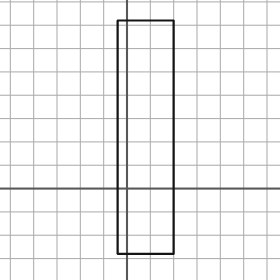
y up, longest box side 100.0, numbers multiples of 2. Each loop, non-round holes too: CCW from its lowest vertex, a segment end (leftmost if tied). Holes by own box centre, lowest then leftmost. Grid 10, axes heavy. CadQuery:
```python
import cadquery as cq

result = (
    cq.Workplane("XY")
    .moveTo(-4.0, -28.0)
    .lineTo(20.0, -28.0)
    .lineTo(20.0, 72.0)
    .lineTo(-4.0, 72.0)
    .close()
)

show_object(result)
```